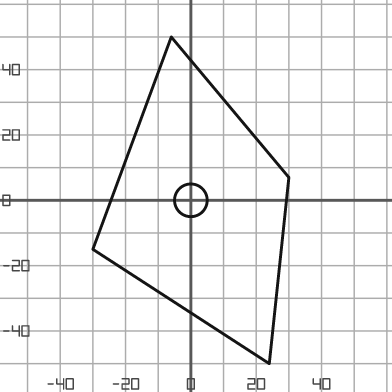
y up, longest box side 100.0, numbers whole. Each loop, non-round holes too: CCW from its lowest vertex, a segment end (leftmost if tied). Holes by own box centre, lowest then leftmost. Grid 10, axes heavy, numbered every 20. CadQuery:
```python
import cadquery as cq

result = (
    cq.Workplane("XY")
    .moveTo(24.0, -50.0)
    .lineTo(30.0, 7.0)
    .lineTo(-6.0, 50.0)
    .lineTo(-30.0, -15.0)
    .close()
    .moveTo(0.0, 0.0)
    .circle(5.0)
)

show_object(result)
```